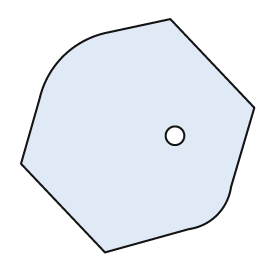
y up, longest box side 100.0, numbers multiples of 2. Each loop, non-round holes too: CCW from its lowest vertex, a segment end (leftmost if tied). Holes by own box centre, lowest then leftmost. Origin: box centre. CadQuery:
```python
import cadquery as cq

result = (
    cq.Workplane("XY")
    .moveTo(-14.0, -50.0)
    .lineTo(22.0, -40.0)
    .threePointArc((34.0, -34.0), (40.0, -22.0))
    .lineTo(50.0, 12.0)
    .lineTo(14.0, 50.0)
    .lineTo(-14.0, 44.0)
    .threePointArc((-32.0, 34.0), (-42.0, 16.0))
    .lineTo(-50.0, -12.0)
    .close()
    .moveTo(16.0, 0.0)
    .circle(4.0)
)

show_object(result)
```